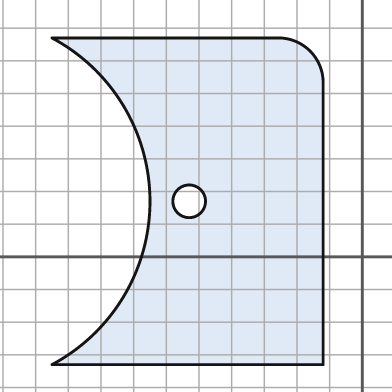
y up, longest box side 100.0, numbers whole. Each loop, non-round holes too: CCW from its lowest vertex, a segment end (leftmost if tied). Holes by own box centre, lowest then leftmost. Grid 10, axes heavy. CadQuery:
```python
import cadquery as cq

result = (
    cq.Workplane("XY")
    .moveTo(-95.0, -33.0)
    .lineTo(-12.0, -33.0)
    .lineTo(-12.0, 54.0)
    .threePointArc((-16.0, 63.0), (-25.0, 67.0))
    .lineTo(-95.0, 67.0)
    .threePointArc((-65.0, 17.0), (-95.0, -33.0))
    .close()
    .moveTo(-53.0, 17.0)
    .circle(5.0)
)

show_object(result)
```